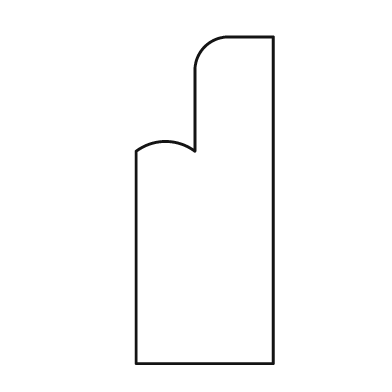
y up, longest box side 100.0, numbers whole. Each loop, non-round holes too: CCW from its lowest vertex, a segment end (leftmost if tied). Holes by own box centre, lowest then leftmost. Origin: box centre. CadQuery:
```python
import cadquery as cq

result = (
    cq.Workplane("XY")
    .moveTo(-21.0, -50.0)
    .lineTo(21.0, -50.0)
    .lineTo(21.0, 50.0)
    .lineTo(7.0, 50.0)
    .threePointArc((0.0, 47.0), (-3.0, 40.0))
    .lineTo(-3.0, 15.0)
    .threePointArc((-12.0, 18.0), (-21.0, 15.0))
    .close()
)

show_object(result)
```